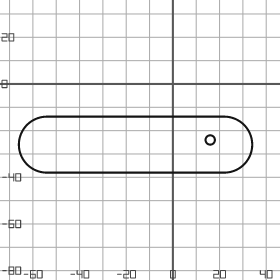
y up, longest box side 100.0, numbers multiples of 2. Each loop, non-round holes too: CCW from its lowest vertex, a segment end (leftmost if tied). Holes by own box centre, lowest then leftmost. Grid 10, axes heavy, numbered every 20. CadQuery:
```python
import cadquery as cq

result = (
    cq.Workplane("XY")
    .moveTo(-54.0, -38.0)
    .lineTo(22.0, -38.0)
    .threePointArc((34.0, -26.0), (22.0, -14.0))
    .lineTo(-54.0, -14.0)
    .threePointArc((-66.0, -26.0), (-54.0, -38.0))
    .close()
    .moveTo(16.0, -24.0)
    .circle(2.0)
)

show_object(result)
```